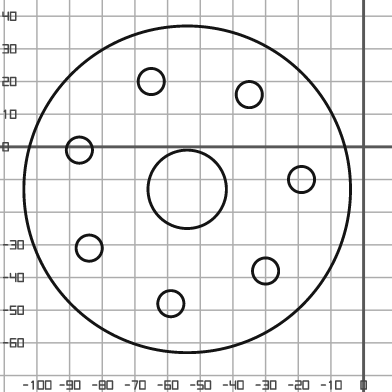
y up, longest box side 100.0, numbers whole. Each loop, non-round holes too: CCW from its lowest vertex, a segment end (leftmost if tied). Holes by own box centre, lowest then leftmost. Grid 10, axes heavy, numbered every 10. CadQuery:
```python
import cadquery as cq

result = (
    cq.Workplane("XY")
    .moveTo(-54.0, -13.0)
    .circle(50.0)
    .moveTo(-59.0, -48.0)
    .circle(4.0)
    .moveTo(-30.0, -38.0)
    .circle(4.0)
    .moveTo(-84.0, -31.0)
    .circle(4.0)
    .moveTo(-54.0, -13.0)
    .circle(12.0)
    .moveTo(-19.0, -10.0)
    .circle(4.0)
    .moveTo(-87.0, -1.0)
    .circle(4.0)
    .moveTo(-35.0, 16.0)
    .circle(4.0)
    .moveTo(-65.0, 20.0)
    .circle(4.0)
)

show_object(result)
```